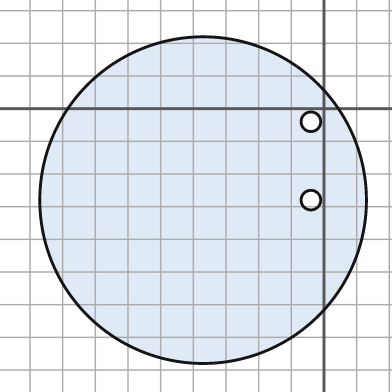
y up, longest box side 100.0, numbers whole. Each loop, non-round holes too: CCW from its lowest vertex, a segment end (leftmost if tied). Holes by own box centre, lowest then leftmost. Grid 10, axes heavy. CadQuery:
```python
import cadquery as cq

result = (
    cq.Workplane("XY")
    .moveTo(-37.0, -28.0)
    .circle(50.0)
    .moveTo(-4.0, -28.0)
    .circle(3.0)
    .moveTo(-4.0, -4.0)
    .circle(3.0)
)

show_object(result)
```